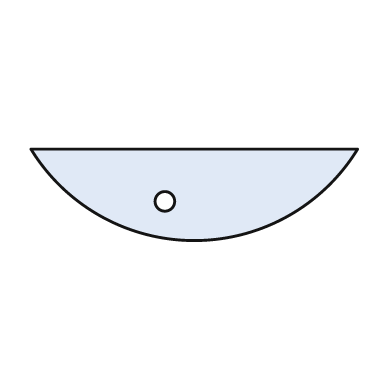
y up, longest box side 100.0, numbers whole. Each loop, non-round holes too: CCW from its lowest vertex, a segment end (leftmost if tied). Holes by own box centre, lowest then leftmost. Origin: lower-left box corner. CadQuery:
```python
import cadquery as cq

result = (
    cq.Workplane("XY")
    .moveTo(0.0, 28.0)
    .threePointArc((50.0, 0.0), (100.0, 28.0))
    .close()
    .moveTo(41.0, 12.0)
    .circle(3.0)
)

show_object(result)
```